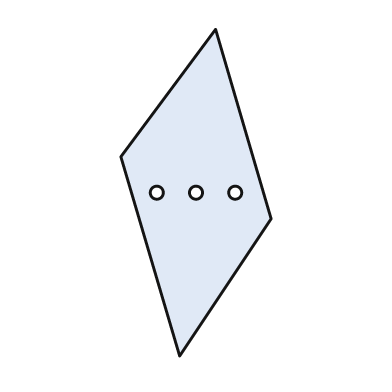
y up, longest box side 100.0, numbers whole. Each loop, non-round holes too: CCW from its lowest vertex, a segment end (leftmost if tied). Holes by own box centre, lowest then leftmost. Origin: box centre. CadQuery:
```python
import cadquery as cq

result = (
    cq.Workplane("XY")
    .moveTo(-5.0, -50.0)
    .lineTo(23.0, -8.0)
    .lineTo(6.0, 50.0)
    .lineTo(-23.0, 11.0)
    .close()
    .moveTo(-12.0, 0.0)
    .circle(2.0)
    .moveTo(0.0, 0.0)
    .circle(2.0)
    .moveTo(12.0, 0.0)
    .circle(2.0)
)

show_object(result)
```